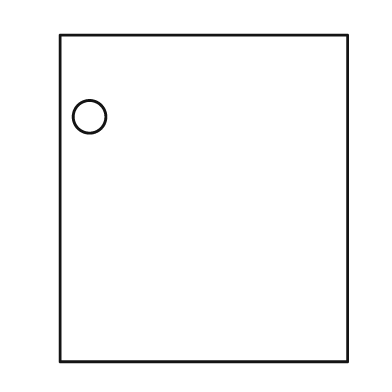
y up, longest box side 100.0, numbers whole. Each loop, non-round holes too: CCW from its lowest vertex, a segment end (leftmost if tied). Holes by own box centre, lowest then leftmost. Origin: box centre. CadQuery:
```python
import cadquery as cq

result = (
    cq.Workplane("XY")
    .moveTo(-44.0, -50.0)
    .lineTo(44.0, -50.0)
    .lineTo(44.0, 50.0)
    .lineTo(-44.0, 50.0)
    .close()
    .moveTo(-35.0, 25.0)
    .circle(5.0)
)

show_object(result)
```